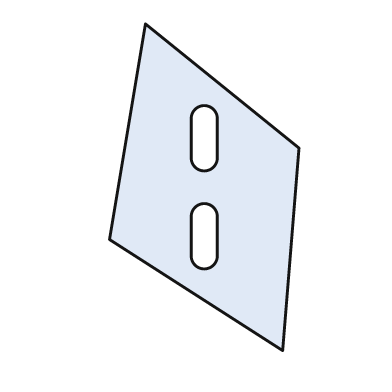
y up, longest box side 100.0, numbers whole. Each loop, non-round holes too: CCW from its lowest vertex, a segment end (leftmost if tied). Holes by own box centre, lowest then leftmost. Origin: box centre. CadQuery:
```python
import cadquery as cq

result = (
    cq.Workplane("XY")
    .moveTo(24.0, -50.0)
    .lineTo(29.0, 12.0)
    .lineTo(-18.0, 50.0)
    .lineTo(-29.0, -16.0)
    .close()
    .moveTo(-4.0, -21.0)
    .threePointArc((0.0, -25.0), (4.0, -21.0))
    .lineTo(4.0, -9.0)
    .threePointArc((0.0, -5.0), (-4.0, -9.0))
    .close()
    .moveTo(-4.0, 9.0)
    .threePointArc((0.0, 5.0), (4.0, 9.0))
    .lineTo(4.0, 21.0)
    .threePointArc((0.0, 25.0), (-4.0, 21.0))
    .close()
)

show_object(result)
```